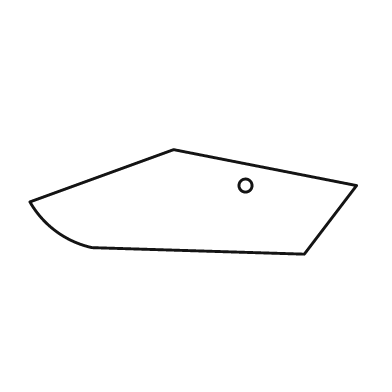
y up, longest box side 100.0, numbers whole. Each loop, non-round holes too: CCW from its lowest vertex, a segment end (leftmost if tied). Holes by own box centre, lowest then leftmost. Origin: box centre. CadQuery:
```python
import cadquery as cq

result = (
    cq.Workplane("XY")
    .moveTo(34.0, -16.0)
    .lineTo(50.0, 5.0)
    .lineTo(-6.0, 16.0)
    .lineTo(-50.0, 0.0)
    .threePointArc((-42.0, -9.0), (-31.0, -14.0))
    .close()
    .moveTo(16.0, 5.0)
    .circle(2.0)
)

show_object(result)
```